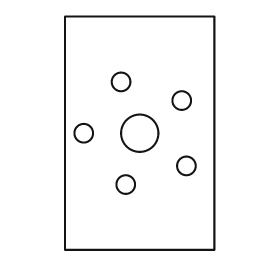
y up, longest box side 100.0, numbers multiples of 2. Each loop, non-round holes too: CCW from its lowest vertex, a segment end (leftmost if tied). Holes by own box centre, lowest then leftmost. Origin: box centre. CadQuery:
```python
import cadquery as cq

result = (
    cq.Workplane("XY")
    .moveTo(-32.0, -50.0)
    .lineTo(32.0, -50.0)
    .lineTo(32.0, 50.0)
    .lineTo(-32.0, 50.0)
    .close()
    .moveTo(-6.0, -22.0)
    .circle(4.0)
    .moveTo(20.0, -14.0)
    .circle(4.0)
    .moveTo(-24.0, 0.0)
    .circle(4.0)
    .moveTo(0.0, 0.0)
    .circle(8.0)
    .moveTo(18.0, 14.0)
    .circle(4.0)
    .moveTo(-8.0, 22.0)
    .circle(4.0)
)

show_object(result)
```